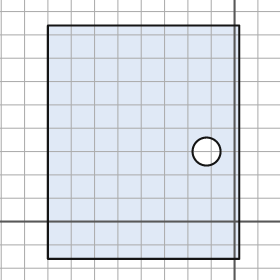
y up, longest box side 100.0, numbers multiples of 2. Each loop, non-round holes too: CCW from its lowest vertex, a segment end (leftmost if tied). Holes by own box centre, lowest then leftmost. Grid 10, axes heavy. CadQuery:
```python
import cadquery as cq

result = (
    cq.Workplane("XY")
    .moveTo(-80.0, -16.0)
    .lineTo(2.0, -16.0)
    .lineTo(2.0, 84.0)
    .lineTo(-80.0, 84.0)
    .close()
    .moveTo(-12.0, 30.0)
    .circle(6.0)
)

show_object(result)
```